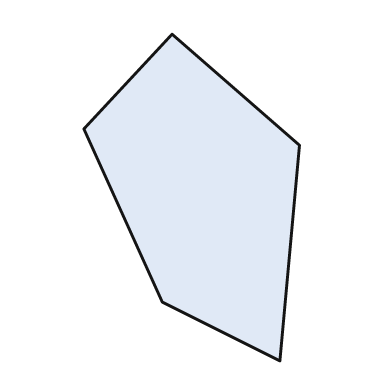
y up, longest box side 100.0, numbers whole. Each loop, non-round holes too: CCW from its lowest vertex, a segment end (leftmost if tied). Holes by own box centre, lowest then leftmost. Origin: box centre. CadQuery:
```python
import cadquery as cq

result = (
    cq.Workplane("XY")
    .moveTo(27.0, -50.0)
    .lineTo(33.0, 16.0)
    .lineTo(-6.0, 50.0)
    .lineTo(-33.0, 21.0)
    .lineTo(-9.0, -32.0)
    .close()
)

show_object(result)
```